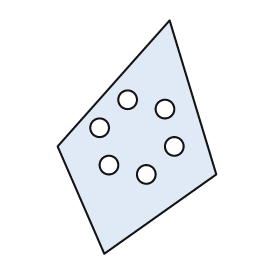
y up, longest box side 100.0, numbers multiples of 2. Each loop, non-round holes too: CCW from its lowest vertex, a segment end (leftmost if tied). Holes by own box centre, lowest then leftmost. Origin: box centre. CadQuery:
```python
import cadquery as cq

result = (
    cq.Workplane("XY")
    .moveTo(-14.0, -50.0)
    .lineTo(34.0, -16.0)
    .lineTo(14.0, 50.0)
    .lineTo(-34.0, -4.0)
    .close()
    .moveTo(4.0, -16.0)
    .circle(4.0)
    .moveTo(-12.0, -12.0)
    .circle(4.0)
    .moveTo(16.0, -4.0)
    .circle(4.0)
    .moveTo(-16.0, 4.0)
    .circle(4.0)
    .moveTo(12.0, 12.0)
    .circle(4.0)
    .moveTo(-4.0, 16.0)
    .circle(4.0)
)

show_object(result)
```